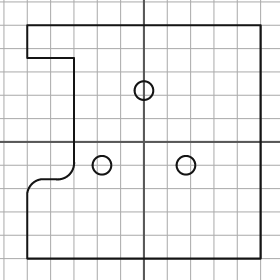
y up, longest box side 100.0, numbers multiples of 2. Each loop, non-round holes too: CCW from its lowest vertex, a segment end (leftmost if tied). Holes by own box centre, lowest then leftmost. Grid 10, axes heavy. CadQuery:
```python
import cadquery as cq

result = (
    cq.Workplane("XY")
    .moveTo(-50.0, -50.0)
    .lineTo(50.0, -50.0)
    .lineTo(50.0, 50.0)
    .lineTo(-50.0, 50.0)
    .lineTo(-50.0, 36.0)
    .lineTo(-30.0, 36.0)
    .lineTo(-30.0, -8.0)
    .threePointArc((-32.0, -14.0), (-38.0, -16.0))
    .lineTo(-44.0, -16.0)
    .threePointArc((-48.0, -18.0), (-50.0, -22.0))
    .close()
    .moveTo(-18.0, -10.0)
    .circle(4.0)
    .moveTo(18.0, -10.0)
    .circle(4.0)
    .moveTo(0.0, 22.0)
    .circle(4.0)
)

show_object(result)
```